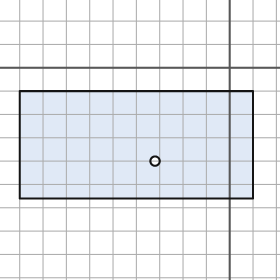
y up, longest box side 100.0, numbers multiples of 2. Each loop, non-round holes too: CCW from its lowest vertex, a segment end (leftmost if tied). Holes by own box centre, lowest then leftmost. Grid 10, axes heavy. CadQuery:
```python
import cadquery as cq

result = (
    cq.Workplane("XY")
    .moveTo(-90.0, -56.0)
    .lineTo(10.0, -56.0)
    .lineTo(10.0, -10.0)
    .lineTo(-90.0, -10.0)
    .close()
    .moveTo(-32.0, -40.0)
    .circle(2.0)
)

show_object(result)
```